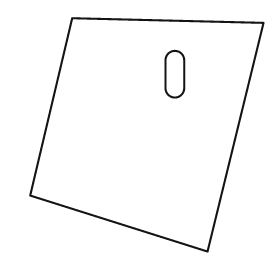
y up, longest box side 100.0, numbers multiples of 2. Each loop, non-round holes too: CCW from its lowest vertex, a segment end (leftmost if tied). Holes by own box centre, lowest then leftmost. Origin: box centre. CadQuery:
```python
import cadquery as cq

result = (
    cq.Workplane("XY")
    .moveTo(26.0, -50.0)
    .lineTo(50.0, 48.0)
    .lineTo(-32.0, 50.0)
    .lineTo(-50.0, -26.0)
    .close()
    .moveTo(8.0, 20.0)
    .threePointArc((12.0, 16.0), (16.0, 20.0))
    .lineTo(16.0, 32.0)
    .threePointArc((12.0, 36.0), (8.0, 32.0))
    .close()
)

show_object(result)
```